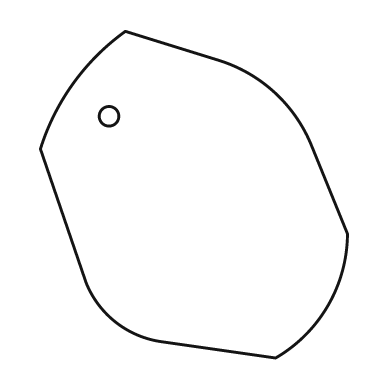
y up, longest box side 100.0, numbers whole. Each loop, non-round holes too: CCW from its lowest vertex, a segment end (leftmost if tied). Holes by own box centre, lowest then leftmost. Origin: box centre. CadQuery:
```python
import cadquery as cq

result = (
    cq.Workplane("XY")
    .moveTo(25.0, -50.0)
    .threePointArc((41.0, -34.0), (47.0, -12.0))
    .lineTo(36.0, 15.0)
    .threePointArc((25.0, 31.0), (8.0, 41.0))
    .lineTo(-21.0, 50.0)
    .threePointArc((-37.0, 34.0), (-47.0, 14.0))
    .lineTo(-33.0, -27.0)
    .threePointArc((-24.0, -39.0), (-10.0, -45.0))
    .close()
    .moveTo(-26.0, 24.0)
    .circle(3.0)
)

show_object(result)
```